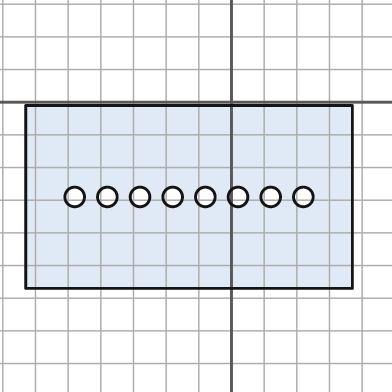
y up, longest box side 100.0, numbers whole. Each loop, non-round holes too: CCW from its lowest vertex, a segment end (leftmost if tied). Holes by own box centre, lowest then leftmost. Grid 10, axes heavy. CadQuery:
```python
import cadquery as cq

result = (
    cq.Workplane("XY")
    .moveTo(-63.0, -57.0)
    .lineTo(37.0, -57.0)
    .lineTo(37.0, -1.0)
    .lineTo(-63.0, -1.0)
    .close()
    .moveTo(-48.0, -29.0)
    .circle(3.0)
    .moveTo(-38.0, -29.0)
    .circle(3.0)
    .moveTo(-28.0, -29.0)
    .circle(3.0)
    .moveTo(-18.0, -29.0)
    .circle(3.0)
    .moveTo(-8.0, -29.0)
    .circle(3.0)
    .moveTo(2.0, -29.0)
    .circle(3.0)
    .moveTo(12.0, -29.0)
    .circle(3.0)
    .moveTo(22.0, -29.0)
    .circle(3.0)
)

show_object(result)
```